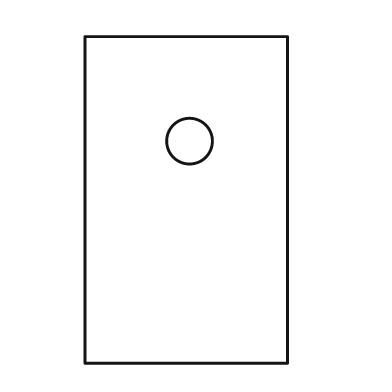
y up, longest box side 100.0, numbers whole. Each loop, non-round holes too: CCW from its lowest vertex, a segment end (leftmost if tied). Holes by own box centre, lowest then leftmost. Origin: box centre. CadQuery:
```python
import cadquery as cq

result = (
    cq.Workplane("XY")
    .moveTo(-31.0, -50.0)
    .lineTo(31.0, -50.0)
    .lineTo(31.0, 50.0)
    .lineTo(-31.0, 50.0)
    .close()
    .moveTo(1.0, 18.0)
    .circle(7.0)
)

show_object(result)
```